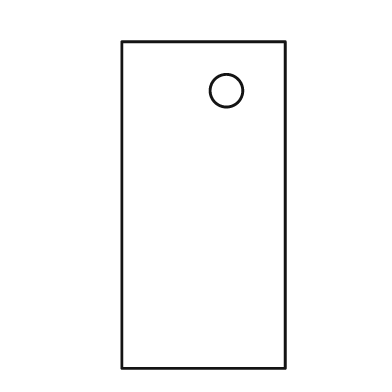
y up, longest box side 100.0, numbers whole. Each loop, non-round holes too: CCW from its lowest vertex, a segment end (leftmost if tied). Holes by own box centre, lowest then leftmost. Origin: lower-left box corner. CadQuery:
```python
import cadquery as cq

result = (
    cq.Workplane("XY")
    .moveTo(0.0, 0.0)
    .lineTo(50.0, 0.0)
    .lineTo(50.0, 100.0)
    .lineTo(0.0, 100.0)
    .close()
    .moveTo(32.0, 85.0)
    .circle(5.0)
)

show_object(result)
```